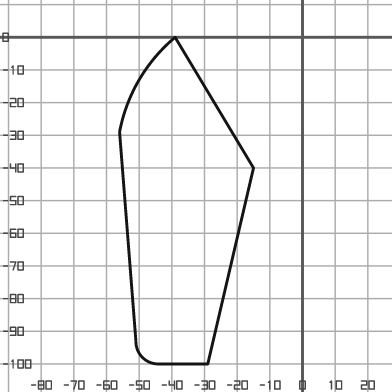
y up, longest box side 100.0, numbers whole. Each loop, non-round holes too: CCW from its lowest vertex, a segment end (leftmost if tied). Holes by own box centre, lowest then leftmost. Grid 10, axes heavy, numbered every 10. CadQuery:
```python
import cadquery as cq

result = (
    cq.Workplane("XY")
    .moveTo(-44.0, -100.0)
    .lineTo(-29.0, -100.0)
    .lineTo(-15.0, -40.0)
    .lineTo(-39.0, 0.0)
    .threePointArc((-50.0, -13.0), (-56.0, -29.0))
    .lineTo(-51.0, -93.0)
    .threePointArc((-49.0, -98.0), (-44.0, -100.0))
    .close()
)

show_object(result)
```